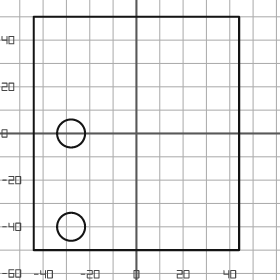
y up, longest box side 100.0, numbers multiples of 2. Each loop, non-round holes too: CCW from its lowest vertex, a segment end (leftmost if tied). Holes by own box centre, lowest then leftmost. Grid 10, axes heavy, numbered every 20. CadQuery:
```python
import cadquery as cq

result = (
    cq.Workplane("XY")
    .moveTo(-44.0, -50.0)
    .lineTo(44.0, -50.0)
    .lineTo(44.0, 50.0)
    .lineTo(-44.0, 50.0)
    .close()
    .moveTo(-28.0, -40.0)
    .circle(6.0)
    .moveTo(-28.0, 0.0)
    .circle(6.0)
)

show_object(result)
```